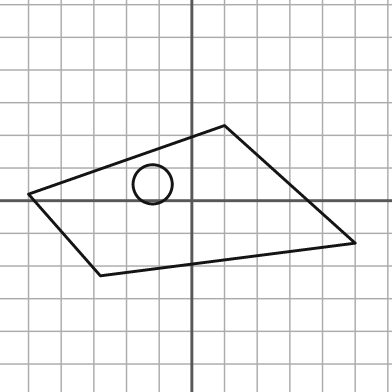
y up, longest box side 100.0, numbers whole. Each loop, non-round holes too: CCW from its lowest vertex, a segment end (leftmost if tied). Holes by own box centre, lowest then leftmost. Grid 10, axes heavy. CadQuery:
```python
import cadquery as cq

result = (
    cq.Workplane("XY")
    .moveTo(-28.0, -23.0)
    .lineTo(50.0, -13.0)
    .lineTo(10.0, 23.0)
    .lineTo(-50.0, 2.0)
    .close()
    .moveTo(-12.0, 5.0)
    .circle(6.0)
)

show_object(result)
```